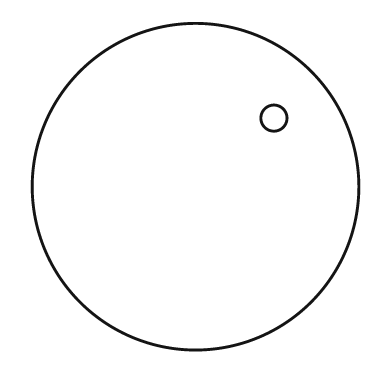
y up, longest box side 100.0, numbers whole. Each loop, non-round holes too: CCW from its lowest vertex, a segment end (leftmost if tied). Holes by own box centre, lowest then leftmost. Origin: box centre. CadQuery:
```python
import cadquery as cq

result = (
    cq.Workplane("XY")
    .moveTo(0.0, 0.0)
    .circle(50.0)
    .moveTo(24.0, 21.0)
    .circle(4.0)
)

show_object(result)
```